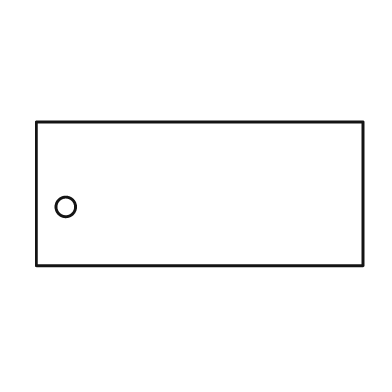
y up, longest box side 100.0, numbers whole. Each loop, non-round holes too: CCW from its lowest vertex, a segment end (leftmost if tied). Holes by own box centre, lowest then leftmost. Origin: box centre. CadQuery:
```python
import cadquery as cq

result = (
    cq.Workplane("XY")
    .moveTo(-50.0, -22.0)
    .lineTo(50.0, -22.0)
    .lineTo(50.0, 22.0)
    .lineTo(-50.0, 22.0)
    .close()
    .moveTo(-41.0, -4.0)
    .circle(3.0)
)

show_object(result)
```